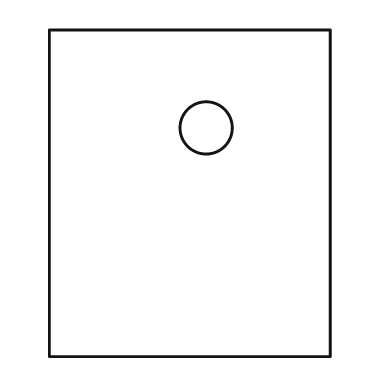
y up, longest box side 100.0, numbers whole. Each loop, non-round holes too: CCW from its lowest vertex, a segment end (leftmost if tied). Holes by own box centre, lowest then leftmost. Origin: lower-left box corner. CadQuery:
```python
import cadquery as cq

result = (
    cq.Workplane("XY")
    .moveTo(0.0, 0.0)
    .lineTo(86.0, 0.0)
    .lineTo(86.0, 100.0)
    .lineTo(0.0, 100.0)
    .close()
    .moveTo(48.0, 70.0)
    .circle(8.0)
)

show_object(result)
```